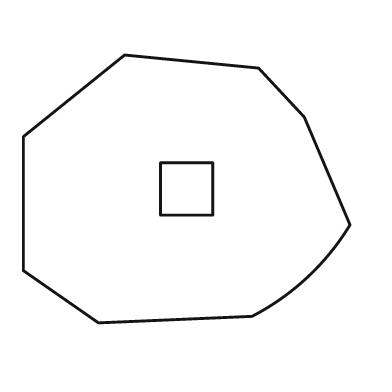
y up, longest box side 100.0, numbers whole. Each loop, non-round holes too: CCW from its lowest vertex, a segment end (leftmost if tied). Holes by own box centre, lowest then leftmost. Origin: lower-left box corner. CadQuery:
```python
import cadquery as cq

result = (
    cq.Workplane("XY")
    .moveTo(23.0, 0.0)
    .lineTo(70.0, 2.0)
    .threePointArc((87.0, 14.0), (100.0, 30.0))
    .lineTo(86.0, 63.0)
    .lineTo(72.0, 78.0)
    .lineTo(31.0, 82.0)
    .lineTo(0.0, 57.0)
    .lineTo(0.0, 16.0)
    .close()
    .moveTo(42.0, 33.0)
    .lineTo(58.0, 33.0)
    .lineTo(58.0, 49.0)
    .lineTo(42.0, 49.0)
    .close()
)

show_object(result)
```